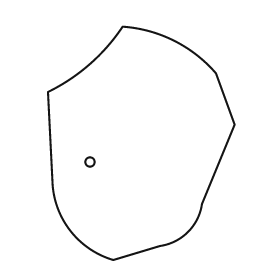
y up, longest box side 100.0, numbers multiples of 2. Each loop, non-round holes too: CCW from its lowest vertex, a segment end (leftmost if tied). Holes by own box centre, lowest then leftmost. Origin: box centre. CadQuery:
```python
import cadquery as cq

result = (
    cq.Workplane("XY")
    .moveTo(-12.0, -50.0)
    .lineTo(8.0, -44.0)
    .threePointArc((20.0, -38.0), (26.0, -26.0))
    .lineTo(40.0, 8.0)
    .lineTo(32.0, 30.0)
    .threePointArc((14.0, 44.0), (-8.0, 50.0))
    .threePointArc((-22.0, 34.0), (-40.0, 22.0))
    .lineTo(-38.0, -18.0)
    .threePointArc((-30.0, -38.0), (-12.0, -50.0))
    .close()
    .moveTo(-22.0, -8.0)
    .circle(2.0)
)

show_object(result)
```